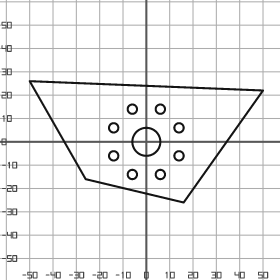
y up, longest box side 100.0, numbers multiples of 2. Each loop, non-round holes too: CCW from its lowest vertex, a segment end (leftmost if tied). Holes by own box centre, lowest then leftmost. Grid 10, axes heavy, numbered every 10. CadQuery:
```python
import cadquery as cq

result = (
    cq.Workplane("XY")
    .moveTo(16.0, -26.0)
    .lineTo(50.0, 22.0)
    .lineTo(-50.0, 26.0)
    .lineTo(-26.0, -16.0)
    .close()
    .moveTo(-6.0, -14.0)
    .circle(2.0)
    .moveTo(6.0, -14.0)
    .circle(2.0)
    .moveTo(-14.0, -6.0)
    .circle(2.0)
    .moveTo(14.0, -6.0)
    .circle(2.0)
    .moveTo(0.0, 0.0)
    .circle(6.0)
    .moveTo(-14.0, 6.0)
    .circle(2.0)
    .moveTo(14.0, 6.0)
    .circle(2.0)
    .moveTo(-6.0, 14.0)
    .circle(2.0)
    .moveTo(6.0, 14.0)
    .circle(2.0)
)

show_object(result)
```